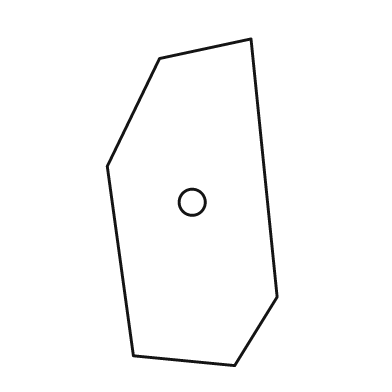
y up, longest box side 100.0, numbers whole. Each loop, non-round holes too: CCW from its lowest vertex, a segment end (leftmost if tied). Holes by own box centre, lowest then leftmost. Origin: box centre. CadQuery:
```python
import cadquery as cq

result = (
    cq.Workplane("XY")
    .moveTo(13.0, -50.0)
    .lineTo(26.0, -29.0)
    .lineTo(18.0, 50.0)
    .lineTo(-10.0, 44.0)
    .lineTo(-26.0, 11.0)
    .lineTo(-18.0, -47.0)
    .close()
    .moveTo(0.0, 0.0)
    .circle(4.0)
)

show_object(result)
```